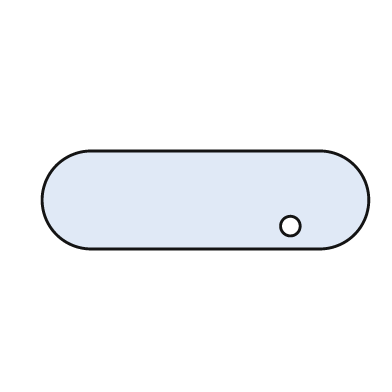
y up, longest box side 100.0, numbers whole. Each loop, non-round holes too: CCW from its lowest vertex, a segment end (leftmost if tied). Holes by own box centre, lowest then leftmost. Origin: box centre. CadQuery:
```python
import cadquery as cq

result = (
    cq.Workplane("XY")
    .moveTo(-35.0, -15.0)
    .lineTo(35.0, -15.0)
    .threePointArc((50.0, 0.0), (35.0, 15.0))
    .lineTo(-35.0, 15.0)
    .threePointArc((-50.0, 0.0), (-35.0, -15.0))
    .close()
    .moveTo(26.0, -8.0)
    .circle(3.0)
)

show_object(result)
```